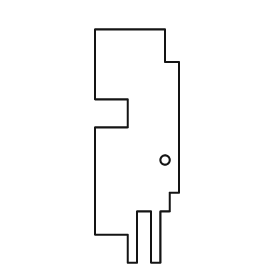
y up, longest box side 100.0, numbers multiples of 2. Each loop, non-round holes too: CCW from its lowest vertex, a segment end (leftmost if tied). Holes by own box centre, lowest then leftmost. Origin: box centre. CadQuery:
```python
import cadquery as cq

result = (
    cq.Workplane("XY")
    .moveTo(-4.0, -50.0)
    .lineTo(0.0, -50.0)
    .lineTo(0.0, -28.0)
    .lineTo(6.0, -28.0)
    .lineTo(6.0, -50.0)
    .lineTo(10.0, -50.0)
    .lineTo(10.0, -28.0)
    .lineTo(14.0, -28.0)
    .lineTo(14.0, -20.0)
    .lineTo(18.0, -20.0)
    .lineTo(18.0, 36.0)
    .lineTo(12.0, 36.0)
    .lineTo(12.0, 50.0)
    .lineTo(-18.0, 50.0)
    .lineTo(-18.0, 20.0)
    .lineTo(-4.0, 20.0)
    .lineTo(-4.0, 8.0)
    .lineTo(-18.0, 8.0)
    .lineTo(-18.0, -38.0)
    .lineTo(-4.0, -38.0)
    .close()
    .moveTo(12.0, -6.0)
    .circle(2.0)
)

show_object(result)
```